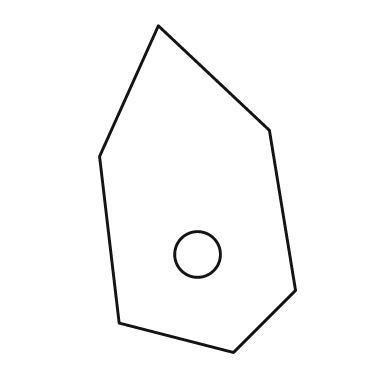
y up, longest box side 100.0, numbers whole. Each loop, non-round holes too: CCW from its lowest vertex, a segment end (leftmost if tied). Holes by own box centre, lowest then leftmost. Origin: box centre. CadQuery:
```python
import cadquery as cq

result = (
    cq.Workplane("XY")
    .moveTo(11.0, -50.0)
    .lineTo(30.0, -31.0)
    .lineTo(22.0, 18.0)
    .lineTo(-12.0, 50.0)
    .lineTo(-30.0, 10.0)
    .lineTo(-24.0, -41.0)
    .close()
    .moveTo(0.0, -20.0)
    .circle(7.0)
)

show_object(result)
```